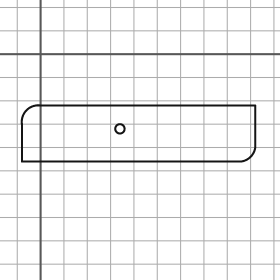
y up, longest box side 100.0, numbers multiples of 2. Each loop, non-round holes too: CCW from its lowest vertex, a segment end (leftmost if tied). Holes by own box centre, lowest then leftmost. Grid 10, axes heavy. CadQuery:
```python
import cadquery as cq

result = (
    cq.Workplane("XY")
    .moveTo(-8.0, -46.0)
    .lineTo(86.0, -46.0)
    .threePointArc((90.0, -44.0), (92.0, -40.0))
    .lineTo(92.0, -22.0)
    .lineTo(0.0, -22.0)
    .threePointArc((-6.0, -24.0), (-8.0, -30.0))
    .close()
    .moveTo(34.0, -32.0)
    .circle(2.0)
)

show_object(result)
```